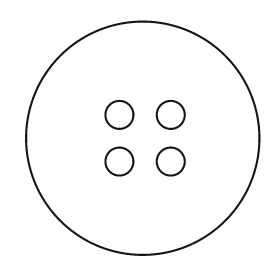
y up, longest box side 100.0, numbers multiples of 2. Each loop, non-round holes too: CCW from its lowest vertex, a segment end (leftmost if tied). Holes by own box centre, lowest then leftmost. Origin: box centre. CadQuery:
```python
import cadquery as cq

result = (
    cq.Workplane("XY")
    .moveTo(0.0, 0.0)
    .circle(50.0)
    .moveTo(-10.0, -10.0)
    .circle(6.0)
    .moveTo(12.0, -10.0)
    .circle(6.0)
    .moveTo(-10.0, 10.0)
    .circle(6.0)
    .moveTo(12.0, 10.0)
    .circle(6.0)
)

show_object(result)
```